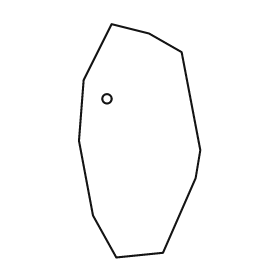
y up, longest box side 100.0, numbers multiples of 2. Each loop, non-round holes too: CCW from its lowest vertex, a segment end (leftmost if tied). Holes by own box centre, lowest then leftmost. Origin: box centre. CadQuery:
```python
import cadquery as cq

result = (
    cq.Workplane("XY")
    .moveTo(-10.0, -50.0)
    .lineTo(10.0, -48.0)
    .lineTo(24.0, -16.0)
    .lineTo(26.0, -4.0)
    .lineTo(18.0, 38.0)
    .lineTo(4.0, 46.0)
    .lineTo(-12.0, 50.0)
    .lineTo(-24.0, 26.0)
    .lineTo(-26.0, 0.0)
    .lineTo(-20.0, -32.0)
    .close()
    .moveTo(-14.0, 18.0)
    .circle(2.0)
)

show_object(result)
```